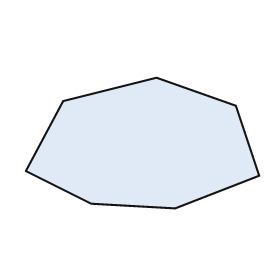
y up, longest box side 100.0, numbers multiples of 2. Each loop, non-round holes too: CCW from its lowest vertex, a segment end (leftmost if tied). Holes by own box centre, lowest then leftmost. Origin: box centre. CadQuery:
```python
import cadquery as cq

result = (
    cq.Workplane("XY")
    .moveTo(14.0, -28.0)
    .lineTo(50.0, -14.0)
    .lineTo(40.0, 16.0)
    .lineTo(6.0, 28.0)
    .lineTo(-34.0, 18.0)
    .lineTo(-50.0, -12.0)
    .lineTo(-22.0, -26.0)
    .close()
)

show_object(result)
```